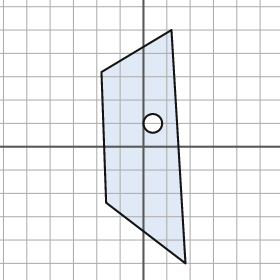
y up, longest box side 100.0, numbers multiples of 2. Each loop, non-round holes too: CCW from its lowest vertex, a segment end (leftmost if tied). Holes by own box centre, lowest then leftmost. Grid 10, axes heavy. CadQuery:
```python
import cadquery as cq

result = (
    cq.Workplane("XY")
    .moveTo(18.0, -50.0)
    .lineTo(12.0, 50.0)
    .lineTo(-18.0, 32.0)
    .lineTo(-16.0, -24.0)
    .close()
    .moveTo(4.0, 10.0)
    .circle(4.0)
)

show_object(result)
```